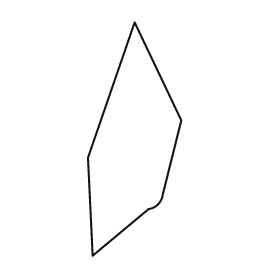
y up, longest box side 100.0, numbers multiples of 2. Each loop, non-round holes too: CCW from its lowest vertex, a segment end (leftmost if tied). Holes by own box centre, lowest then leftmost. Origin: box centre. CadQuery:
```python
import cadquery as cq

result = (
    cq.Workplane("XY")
    .moveTo(-18.0, -50.0)
    .lineTo(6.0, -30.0)
    .threePointArc((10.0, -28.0), (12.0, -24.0))
    .lineTo(20.0, 8.0)
    .lineTo(0.0, 50.0)
    .lineTo(-20.0, -8.0)
    .close()
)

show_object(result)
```